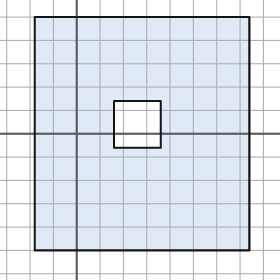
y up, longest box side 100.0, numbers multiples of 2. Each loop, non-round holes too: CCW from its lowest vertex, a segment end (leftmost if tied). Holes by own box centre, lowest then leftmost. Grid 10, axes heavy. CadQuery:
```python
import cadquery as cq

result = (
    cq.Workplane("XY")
    .moveTo(-18.0, -50.0)
    .lineTo(74.0, -50.0)
    .lineTo(74.0, 50.0)
    .lineTo(-18.0, 50.0)
    .close()
    .moveTo(16.0, -6.0)
    .lineTo(36.0, -6.0)
    .lineTo(36.0, 14.0)
    .lineTo(16.0, 14.0)
    .close()
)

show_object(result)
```